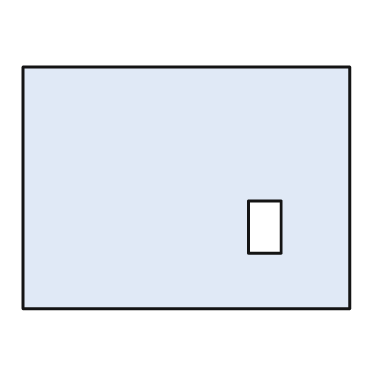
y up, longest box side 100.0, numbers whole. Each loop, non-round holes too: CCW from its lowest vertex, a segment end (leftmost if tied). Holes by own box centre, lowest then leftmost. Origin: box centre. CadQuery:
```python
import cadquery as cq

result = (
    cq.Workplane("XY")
    .moveTo(-50.0, -37.0)
    .lineTo(50.0, -37.0)
    .lineTo(50.0, 37.0)
    .lineTo(-50.0, 37.0)
    .close()
    .moveTo(19.0, -20.0)
    .lineTo(29.0, -20.0)
    .lineTo(29.0, -4.0)
    .lineTo(19.0, -4.0)
    .close()
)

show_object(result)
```